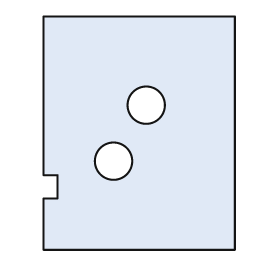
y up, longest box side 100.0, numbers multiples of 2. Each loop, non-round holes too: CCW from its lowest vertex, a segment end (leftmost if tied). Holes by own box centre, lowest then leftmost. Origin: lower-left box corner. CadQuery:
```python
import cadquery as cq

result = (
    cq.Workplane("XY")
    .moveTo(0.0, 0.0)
    .lineTo(82.0, 0.0)
    .lineTo(82.0, 100.0)
    .lineTo(0.0, 100.0)
    .lineTo(0.0, 32.0)
    .lineTo(6.0, 32.0)
    .lineTo(6.0, 22.0)
    .lineTo(0.0, 22.0)
    .close()
    .moveTo(30.0, 38.0)
    .circle(8.0)
    .moveTo(44.0, 62.0)
    .circle(8.0)
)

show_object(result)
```